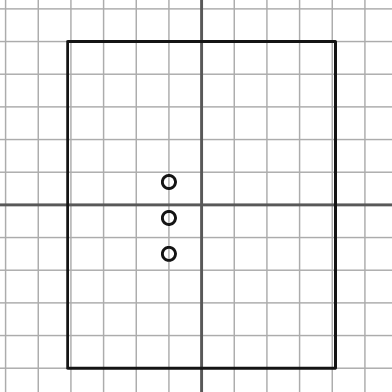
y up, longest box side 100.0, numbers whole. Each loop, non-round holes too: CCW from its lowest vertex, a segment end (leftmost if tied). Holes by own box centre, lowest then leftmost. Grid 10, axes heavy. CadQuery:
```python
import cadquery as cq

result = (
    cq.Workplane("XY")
    .moveTo(-41.0, -50.0)
    .lineTo(41.0, -50.0)
    .lineTo(41.0, 50.0)
    .lineTo(-41.0, 50.0)
    .close()
    .moveTo(-10.0, -15.0)
    .circle(2.0)
    .moveTo(-10.0, -4.0)
    .circle(2.0)
    .moveTo(-10.0, 7.0)
    .circle(2.0)
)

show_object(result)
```